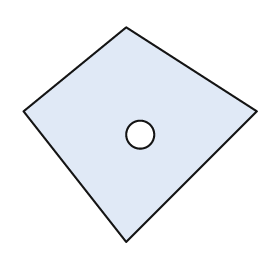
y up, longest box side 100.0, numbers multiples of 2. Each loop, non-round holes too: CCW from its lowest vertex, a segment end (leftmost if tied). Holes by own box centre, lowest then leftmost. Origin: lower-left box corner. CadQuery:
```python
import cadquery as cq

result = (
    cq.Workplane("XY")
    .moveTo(44.0, 0.0)
    .lineTo(100.0, 56.0)
    .lineTo(44.0, 92.0)
    .lineTo(0.0, 56.0)
    .close()
    .moveTo(50.0, 46.0)
    .circle(6.0)
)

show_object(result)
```